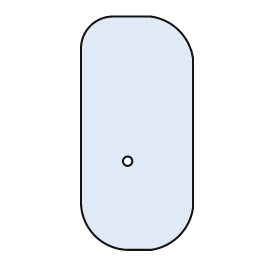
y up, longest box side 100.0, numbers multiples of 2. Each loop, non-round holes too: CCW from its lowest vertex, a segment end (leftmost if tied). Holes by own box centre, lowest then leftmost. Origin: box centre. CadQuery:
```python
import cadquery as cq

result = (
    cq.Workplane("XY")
    .moveTo(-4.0, -50.0)
    .lineTo(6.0, -50.0)
    .threePointArc((18.0, -44.0), (24.0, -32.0))
    .lineTo(24.0, 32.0)
    .threePointArc((18.0, 44.0), (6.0, 50.0))
    .lineTo(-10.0, 50.0)
    .threePointArc((-20.0, 46.0), (-24.0, 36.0))
    .lineTo(-24.0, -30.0)
    .threePointArc((-18.0, -44.0), (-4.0, -50.0))
    .close()
    .moveTo(-4.0, -12.0)
    .circle(2.0)
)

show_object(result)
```